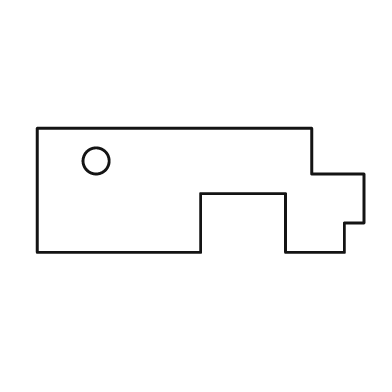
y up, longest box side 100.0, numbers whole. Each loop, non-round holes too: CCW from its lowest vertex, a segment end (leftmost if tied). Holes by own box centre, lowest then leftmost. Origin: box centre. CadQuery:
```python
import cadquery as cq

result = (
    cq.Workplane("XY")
    .moveTo(-50.0, -19.0)
    .lineTo(0.0, -19.0)
    .lineTo(0.0, -1.0)
    .lineTo(26.0, -1.0)
    .lineTo(26.0, -19.0)
    .lineTo(44.0, -19.0)
    .lineTo(44.0, -10.0)
    .lineTo(50.0, -10.0)
    .lineTo(50.0, 5.0)
    .lineTo(34.0, 5.0)
    .lineTo(34.0, 19.0)
    .lineTo(-50.0, 19.0)
    .close()
    .moveTo(-32.0, 9.0)
    .circle(4.0)
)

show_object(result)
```